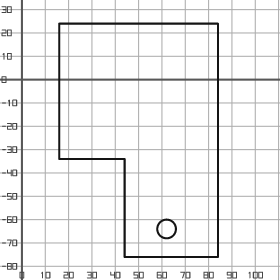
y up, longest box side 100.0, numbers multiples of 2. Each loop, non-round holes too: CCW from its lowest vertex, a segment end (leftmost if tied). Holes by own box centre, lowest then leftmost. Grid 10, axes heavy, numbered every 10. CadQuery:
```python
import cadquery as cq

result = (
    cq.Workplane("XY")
    .moveTo(44.0, -76.0)
    .lineTo(84.0, -76.0)
    .lineTo(84.0, 24.0)
    .lineTo(16.0, 24.0)
    .lineTo(16.0, -34.0)
    .lineTo(44.0, -34.0)
    .close()
    .moveTo(62.0, -64.0)
    .circle(4.0)
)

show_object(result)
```